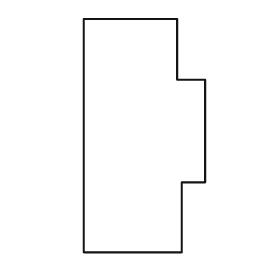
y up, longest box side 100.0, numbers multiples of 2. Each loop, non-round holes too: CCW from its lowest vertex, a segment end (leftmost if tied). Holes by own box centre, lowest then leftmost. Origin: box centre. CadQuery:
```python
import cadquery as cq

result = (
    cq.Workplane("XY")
    .moveTo(-26.0, -50.0)
    .lineTo(16.0, -50.0)
    .lineTo(16.0, -20.0)
    .lineTo(26.0, -20.0)
    .lineTo(26.0, 24.0)
    .lineTo(14.0, 24.0)
    .lineTo(14.0, 50.0)
    .lineTo(-26.0, 50.0)
    .close()
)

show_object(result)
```